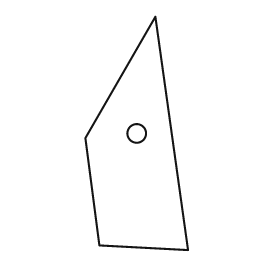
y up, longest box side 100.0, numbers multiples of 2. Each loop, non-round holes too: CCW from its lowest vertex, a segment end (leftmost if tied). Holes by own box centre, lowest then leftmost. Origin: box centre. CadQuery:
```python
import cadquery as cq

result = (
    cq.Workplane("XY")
    .moveTo(22.0, -50.0)
    .lineTo(8.0, 50.0)
    .lineTo(-22.0, -2.0)
    .lineTo(-16.0, -48.0)
    .close()
    .moveTo(0.0, 0.0)
    .circle(4.0)
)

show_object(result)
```